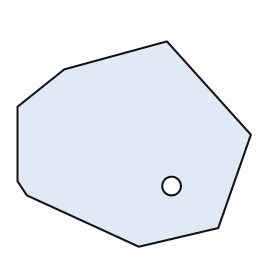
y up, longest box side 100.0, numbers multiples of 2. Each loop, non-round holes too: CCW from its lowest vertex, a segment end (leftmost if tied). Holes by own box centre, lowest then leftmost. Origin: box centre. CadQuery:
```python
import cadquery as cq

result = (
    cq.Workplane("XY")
    .moveTo(2.0, -44.0)
    .lineTo(36.0, -36.0)
    .lineTo(50.0, 4.0)
    .lineTo(14.0, 44.0)
    .lineTo(-30.0, 32.0)
    .lineTo(-50.0, 16.0)
    .lineTo(-50.0, -16.0)
    .lineTo(-46.0, -22.0)
    .close()
    .moveTo(16.0, -18.0)
    .circle(4.0)
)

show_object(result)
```